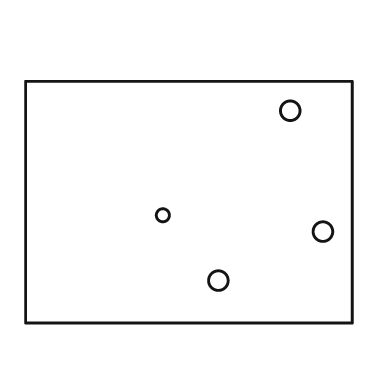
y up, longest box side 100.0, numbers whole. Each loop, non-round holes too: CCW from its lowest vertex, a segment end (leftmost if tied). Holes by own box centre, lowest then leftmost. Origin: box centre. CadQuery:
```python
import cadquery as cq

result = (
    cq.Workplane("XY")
    .moveTo(-50.0, -37.0)
    .lineTo(50.0, -37.0)
    .lineTo(50.0, 37.0)
    .lineTo(-50.0, 37.0)
    .close()
    .moveTo(9.0, -24.0)
    .circle(3.0)
    .moveTo(41.0, -9.0)
    .circle(3.0)
    .moveTo(-8.0, -4.0)
    .circle(2.0)
    .moveTo(31.0, 28.0)
    .circle(3.0)
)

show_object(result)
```